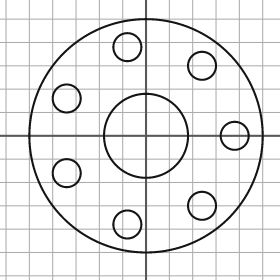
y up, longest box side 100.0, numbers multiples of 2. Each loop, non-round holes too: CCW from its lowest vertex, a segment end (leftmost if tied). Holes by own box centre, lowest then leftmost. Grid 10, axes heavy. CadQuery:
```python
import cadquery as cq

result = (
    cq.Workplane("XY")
    .moveTo(0.0, 0.0)
    .circle(50.0)
    .moveTo(-8.0, -38.0)
    .circle(6.0)
    .moveTo(24.0, -30.0)
    .circle(6.0)
    .moveTo(-34.0, -16.0)
    .circle(6.0)
    .moveTo(0.0, 0.0)
    .circle(18.0)
    .moveTo(38.0, 0.0)
    .circle(6.0)
    .moveTo(-34.0, 16.0)
    .circle(6.0)
    .moveTo(24.0, 30.0)
    .circle(6.0)
    .moveTo(-8.0, 38.0)
    .circle(6.0)
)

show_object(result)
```